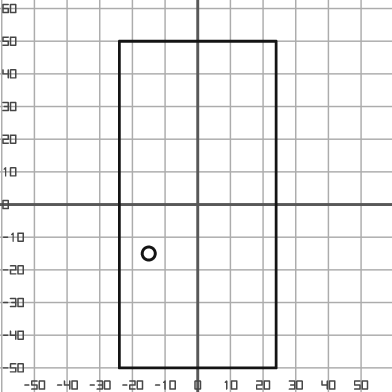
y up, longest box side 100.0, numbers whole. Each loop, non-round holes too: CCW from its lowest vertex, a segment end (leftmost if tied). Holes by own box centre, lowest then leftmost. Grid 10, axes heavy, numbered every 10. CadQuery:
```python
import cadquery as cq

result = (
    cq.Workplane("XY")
    .moveTo(-24.0, -50.0)
    .lineTo(24.0, -50.0)
    .lineTo(24.0, 50.0)
    .lineTo(-24.0, 50.0)
    .close()
    .moveTo(-15.0, -15.0)
    .circle(2.0)
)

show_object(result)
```